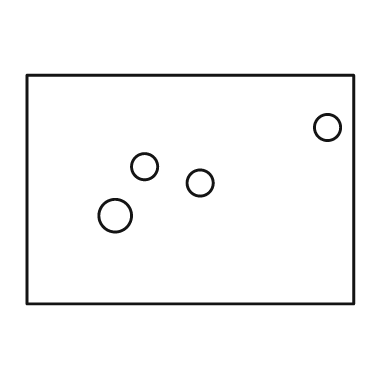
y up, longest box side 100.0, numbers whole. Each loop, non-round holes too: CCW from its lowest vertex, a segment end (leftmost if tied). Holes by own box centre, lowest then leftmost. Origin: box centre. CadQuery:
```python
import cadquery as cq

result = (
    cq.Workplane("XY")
    .moveTo(-50.0, -35.0)
    .lineTo(50.0, -35.0)
    .lineTo(50.0, 35.0)
    .lineTo(-50.0, 35.0)
    .close()
    .moveTo(-23.0, -8.0)
    .circle(5.0)
    .moveTo(3.0, 2.0)
    .circle(4.0)
    .moveTo(-14.0, 7.0)
    .circle(4.0)
    .moveTo(42.0, 19.0)
    .circle(4.0)
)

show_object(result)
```